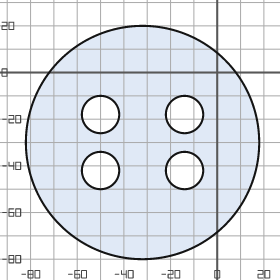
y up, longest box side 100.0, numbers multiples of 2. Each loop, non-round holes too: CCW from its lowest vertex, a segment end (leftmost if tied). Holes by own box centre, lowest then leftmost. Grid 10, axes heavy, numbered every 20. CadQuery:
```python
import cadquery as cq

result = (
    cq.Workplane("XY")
    .moveTo(-32.0, -30.0)
    .circle(50.0)
    .moveTo(-50.0, -42.0)
    .circle(8.0)
    .moveTo(-14.0, -42.0)
    .circle(8.0)
    .moveTo(-50.0, -18.0)
    .circle(8.0)
    .moveTo(-14.0, -18.0)
    .circle(8.0)
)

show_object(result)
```